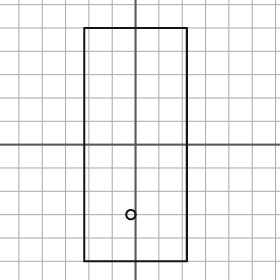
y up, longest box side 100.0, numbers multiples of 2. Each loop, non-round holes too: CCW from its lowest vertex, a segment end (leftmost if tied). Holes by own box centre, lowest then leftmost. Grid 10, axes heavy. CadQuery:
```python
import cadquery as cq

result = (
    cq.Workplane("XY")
    .moveTo(-22.0, -50.0)
    .lineTo(22.0, -50.0)
    .lineTo(22.0, 50.0)
    .lineTo(-22.0, 50.0)
    .close()
    .moveTo(-2.0, -30.0)
    .circle(2.0)
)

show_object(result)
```